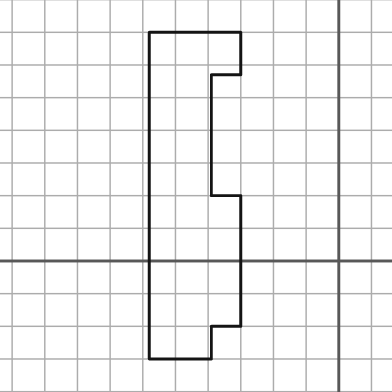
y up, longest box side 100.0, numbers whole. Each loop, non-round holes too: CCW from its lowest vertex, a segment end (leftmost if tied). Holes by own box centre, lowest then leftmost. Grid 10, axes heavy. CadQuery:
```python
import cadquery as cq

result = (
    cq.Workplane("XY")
    .moveTo(-58.0, -30.0)
    .lineTo(-39.0, -30.0)
    .lineTo(-39.0, -20.0)
    .lineTo(-30.0, -20.0)
    .lineTo(-30.0, 20.0)
    .lineTo(-39.0, 20.0)
    .lineTo(-39.0, 57.0)
    .lineTo(-30.0, 57.0)
    .lineTo(-30.0, 70.0)
    .lineTo(-58.0, 70.0)
    .close()
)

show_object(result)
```